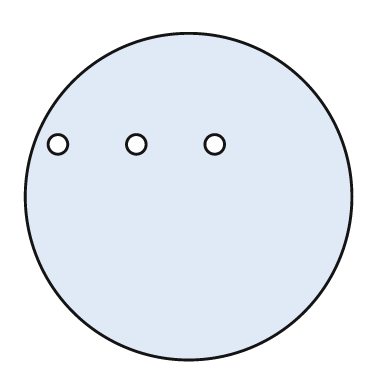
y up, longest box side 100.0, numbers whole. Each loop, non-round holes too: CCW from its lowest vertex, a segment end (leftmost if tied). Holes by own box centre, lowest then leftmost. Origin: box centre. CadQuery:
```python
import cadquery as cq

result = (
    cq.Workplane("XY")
    .moveTo(0.0, 0.0)
    .circle(50.0)
    .moveTo(-40.0, 16.0)
    .circle(3.0)
    .moveTo(-16.0, 16.0)
    .circle(3.0)
    .moveTo(8.0, 16.0)
    .circle(3.0)
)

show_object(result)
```